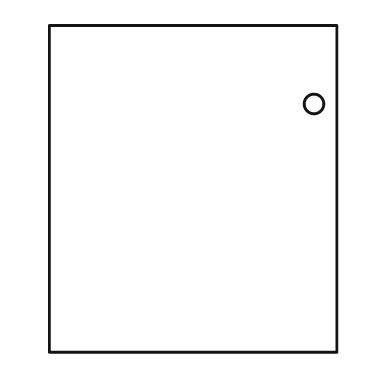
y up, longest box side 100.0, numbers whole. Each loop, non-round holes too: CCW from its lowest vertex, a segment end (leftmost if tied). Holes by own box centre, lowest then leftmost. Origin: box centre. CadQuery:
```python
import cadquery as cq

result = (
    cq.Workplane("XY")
    .moveTo(-44.0, -50.0)
    .lineTo(44.0, -50.0)
    .lineTo(44.0, 50.0)
    .lineTo(-44.0, 50.0)
    .close()
    .moveTo(37.0, 26.0)
    .circle(3.0)
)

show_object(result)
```